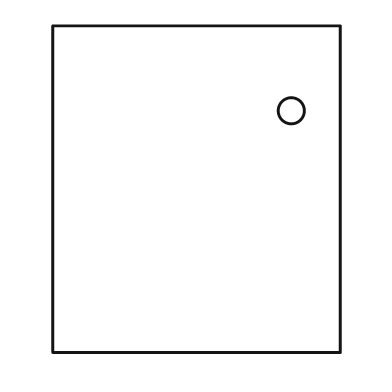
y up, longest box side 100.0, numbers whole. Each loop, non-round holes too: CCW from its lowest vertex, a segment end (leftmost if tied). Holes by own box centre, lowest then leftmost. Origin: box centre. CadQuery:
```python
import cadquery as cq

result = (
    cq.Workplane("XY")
    .moveTo(-44.0, -50.0)
    .lineTo(44.0, -50.0)
    .lineTo(44.0, 50.0)
    .lineTo(-44.0, 50.0)
    .close()
    .moveTo(29.0, 24.0)
    .circle(4.0)
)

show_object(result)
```